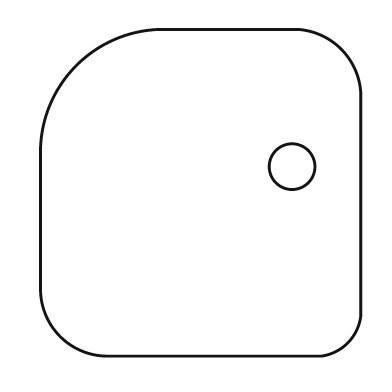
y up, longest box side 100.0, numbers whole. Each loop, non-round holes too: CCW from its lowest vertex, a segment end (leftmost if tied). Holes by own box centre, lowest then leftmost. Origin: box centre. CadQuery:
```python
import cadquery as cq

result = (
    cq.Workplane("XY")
    .moveTo(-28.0, -50.0)
    .lineTo(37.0, -50.0)
    .threePointArc((45.0, -46.0), (49.0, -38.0))
    .lineTo(49.0, 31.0)
    .threePointArc((43.0, 44.0), (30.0, 50.0))
    .lineTo(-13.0, 50.0)
    .threePointArc((-38.0, 39.0), (-49.0, 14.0))
    .lineTo(-49.0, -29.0)
    .threePointArc((-43.0, -44.0), (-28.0, -50.0))
    .close()
    .moveTo(28.0, 8.0)
    .circle(7.0)
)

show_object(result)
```